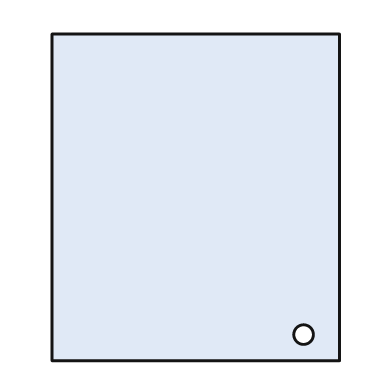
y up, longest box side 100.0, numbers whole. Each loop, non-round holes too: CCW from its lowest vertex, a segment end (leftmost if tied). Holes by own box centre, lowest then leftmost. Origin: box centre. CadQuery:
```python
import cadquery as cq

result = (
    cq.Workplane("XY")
    .moveTo(-44.0, -50.0)
    .lineTo(44.0, -50.0)
    .lineTo(44.0, 50.0)
    .lineTo(-44.0, 50.0)
    .close()
    .moveTo(33.0, -42.0)
    .circle(3.0)
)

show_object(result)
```